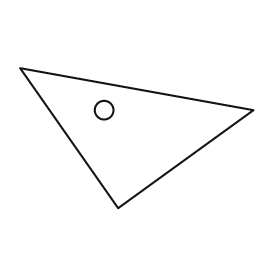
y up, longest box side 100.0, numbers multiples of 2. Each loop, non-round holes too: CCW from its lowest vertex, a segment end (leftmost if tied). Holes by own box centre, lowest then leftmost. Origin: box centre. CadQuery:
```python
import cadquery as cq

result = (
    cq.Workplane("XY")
    .moveTo(-8.0, -30.0)
    .lineTo(50.0, 12.0)
    .lineTo(-50.0, 30.0)
    .close()
    .moveTo(-14.0, 12.0)
    .circle(4.0)
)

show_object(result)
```